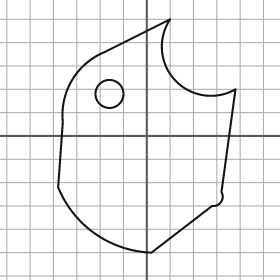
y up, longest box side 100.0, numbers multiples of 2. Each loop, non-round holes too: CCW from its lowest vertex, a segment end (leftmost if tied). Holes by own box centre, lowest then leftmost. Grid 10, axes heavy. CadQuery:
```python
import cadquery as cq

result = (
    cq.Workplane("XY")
    .moveTo(2.0, -50.0)
    .lineTo(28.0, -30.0)
    .threePointArc((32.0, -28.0), (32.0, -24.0))
    .lineTo(38.0, 20.0)
    .threePointArc((12.0, 24.0), (10.0, 50.0))
    .lineTo(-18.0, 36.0)
    .threePointArc((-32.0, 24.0), (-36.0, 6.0))
    .lineTo(-38.0, -22.0)
    .threePointArc((-22.0, -42.0), (2.0, -50.0))
    .close()
    .moveTo(-16.0, 18.0)
    .circle(6.0)
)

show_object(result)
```